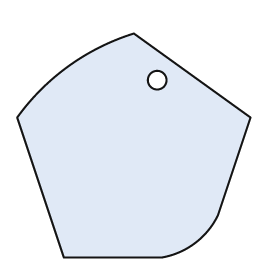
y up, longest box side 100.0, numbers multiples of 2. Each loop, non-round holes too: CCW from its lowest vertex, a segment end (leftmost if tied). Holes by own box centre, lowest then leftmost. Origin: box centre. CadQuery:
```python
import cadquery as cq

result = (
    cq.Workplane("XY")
    .moveTo(-30.0, -48.0)
    .lineTo(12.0, -48.0)
    .threePointArc((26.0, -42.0), (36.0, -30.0))
    .lineTo(50.0, 12.0)
    .lineTo(0.0, 48.0)
    .threePointArc((-28.0, 34.0), (-50.0, 12.0))
    .close()
    .moveTo(10.0, 28.0)
    .circle(4.0)
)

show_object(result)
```